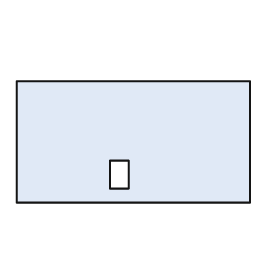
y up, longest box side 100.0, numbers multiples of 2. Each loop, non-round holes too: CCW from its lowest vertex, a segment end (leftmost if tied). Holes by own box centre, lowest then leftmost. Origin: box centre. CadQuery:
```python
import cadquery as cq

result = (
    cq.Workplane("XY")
    .moveTo(-50.0, -26.0)
    .lineTo(50.0, -26.0)
    .lineTo(50.0, 26.0)
    .lineTo(-50.0, 26.0)
    .close()
    .moveTo(-10.0, -20.0)
    .lineTo(-2.0, -20.0)
    .lineTo(-2.0, -8.0)
    .lineTo(-10.0, -8.0)
    .close()
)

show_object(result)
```